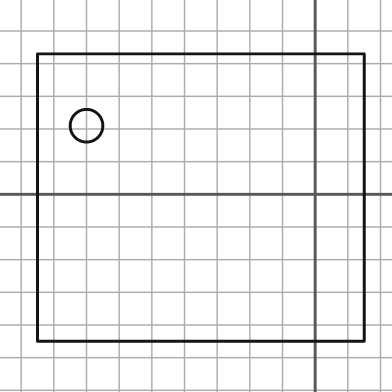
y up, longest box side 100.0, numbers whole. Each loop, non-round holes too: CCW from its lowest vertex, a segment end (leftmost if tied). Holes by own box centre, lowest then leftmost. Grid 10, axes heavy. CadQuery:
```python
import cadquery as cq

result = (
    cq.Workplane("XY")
    .moveTo(-85.0, -45.0)
    .lineTo(15.0, -45.0)
    .lineTo(15.0, 43.0)
    .lineTo(-85.0, 43.0)
    .close()
    .moveTo(-70.0, 21.0)
    .circle(5.0)
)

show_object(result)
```